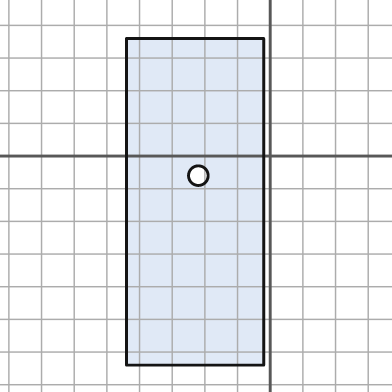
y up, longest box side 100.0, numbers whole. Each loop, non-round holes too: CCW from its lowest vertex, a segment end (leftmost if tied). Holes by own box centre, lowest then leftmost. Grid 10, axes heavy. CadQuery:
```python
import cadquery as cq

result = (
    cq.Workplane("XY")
    .moveTo(-44.0, -64.0)
    .lineTo(-2.0, -64.0)
    .lineTo(-2.0, 36.0)
    .lineTo(-44.0, 36.0)
    .close()
    .moveTo(-22.0, -6.0)
    .circle(3.0)
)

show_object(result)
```